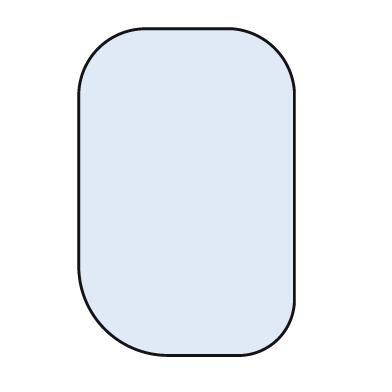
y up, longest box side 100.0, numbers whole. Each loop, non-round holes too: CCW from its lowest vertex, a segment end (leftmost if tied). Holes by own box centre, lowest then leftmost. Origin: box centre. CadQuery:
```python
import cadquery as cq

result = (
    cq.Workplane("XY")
    .moveTo(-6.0, -50.0)
    .lineTo(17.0, -50.0)
    .threePointArc((28.0, -45.0), (33.0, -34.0))
    .lineTo(33.0, 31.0)
    .threePointArc((27.0, 44.0), (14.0, 50.0))
    .lineTo(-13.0, 50.0)
    .threePointArc((-27.0, 44.0), (-33.0, 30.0))
    .lineTo(-33.0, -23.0)
    .threePointArc((-25.0, -42.0), (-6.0, -50.0))
    .close()
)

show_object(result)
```